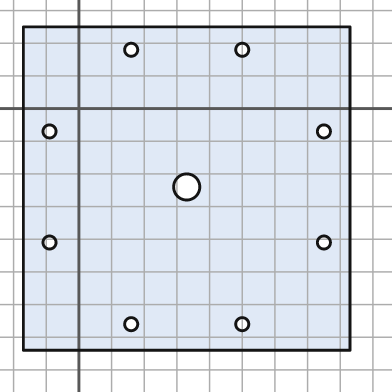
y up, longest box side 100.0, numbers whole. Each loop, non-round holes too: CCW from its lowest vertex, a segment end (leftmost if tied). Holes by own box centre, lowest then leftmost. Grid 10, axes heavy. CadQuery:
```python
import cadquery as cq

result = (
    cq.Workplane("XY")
    .moveTo(-17.0, -74.0)
    .lineTo(83.0, -74.0)
    .lineTo(83.0, 25.0)
    .lineTo(-17.0, 25.0)
    .close()
    .moveTo(16.0, -66.0)
    .circle(2.0)
    .moveTo(50.0, -66.0)
    .circle(2.0)
    .moveTo(-9.0, -41.0)
    .circle(2.0)
    .moveTo(75.0, -41.0)
    .circle(2.0)
    .moveTo(33.0, -24.0)
    .circle(4.0)
    .moveTo(-9.0, -7.0)
    .circle(2.0)
    .moveTo(75.0, -7.0)
    .circle(2.0)
    .moveTo(16.0, 18.0)
    .circle(2.0)
    .moveTo(50.0, 18.0)
    .circle(2.0)
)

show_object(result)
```